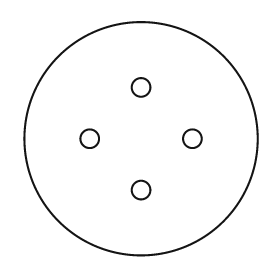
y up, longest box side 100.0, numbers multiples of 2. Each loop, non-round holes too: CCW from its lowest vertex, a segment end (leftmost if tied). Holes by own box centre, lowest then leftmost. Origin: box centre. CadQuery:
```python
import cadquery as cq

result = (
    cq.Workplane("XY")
    .moveTo(0.0, 0.0)
    .circle(50.0)
    .moveTo(0.0, -22.0)
    .circle(4.0)
    .moveTo(-22.0, 0.0)
    .circle(4.0)
    .moveTo(22.0, 0.0)
    .circle(4.0)
    .moveTo(0.0, 22.0)
    .circle(4.0)
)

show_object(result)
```